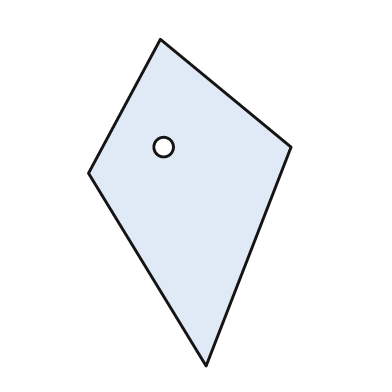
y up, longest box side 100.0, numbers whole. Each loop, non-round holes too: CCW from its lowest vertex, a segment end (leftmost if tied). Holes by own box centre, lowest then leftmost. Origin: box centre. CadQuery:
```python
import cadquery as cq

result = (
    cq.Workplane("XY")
    .moveTo(5.0, -50.0)
    .lineTo(31.0, 17.0)
    .lineTo(-9.0, 50.0)
    .lineTo(-31.0, 9.0)
    .close()
    .moveTo(-8.0, 17.0)
    .circle(3.0)
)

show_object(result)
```